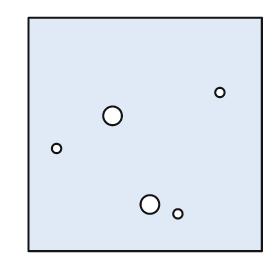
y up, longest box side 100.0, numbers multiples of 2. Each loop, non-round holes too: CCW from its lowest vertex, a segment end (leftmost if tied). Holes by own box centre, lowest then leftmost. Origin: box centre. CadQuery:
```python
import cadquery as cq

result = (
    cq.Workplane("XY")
    .moveTo(-50.0, -50.0)
    .lineTo(50.0, -50.0)
    .lineTo(50.0, 50.0)
    .lineTo(-50.0, 50.0)
    .close()
    .moveTo(14.0, -34.0)
    .circle(2.0)
    .moveTo(2.0, -30.0)
    .circle(4.0)
    .moveTo(-38.0, -6.0)
    .circle(2.0)
    .moveTo(-14.0, 8.0)
    .circle(4.0)
    .moveTo(32.0, 18.0)
    .circle(2.0)
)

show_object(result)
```